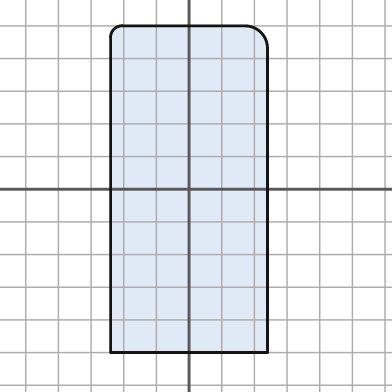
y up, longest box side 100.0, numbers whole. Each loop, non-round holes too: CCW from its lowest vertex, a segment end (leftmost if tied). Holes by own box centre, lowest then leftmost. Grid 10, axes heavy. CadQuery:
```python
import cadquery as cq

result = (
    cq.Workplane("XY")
    .moveTo(-24.0, -50.0)
    .lineTo(24.0, -50.0)
    .lineTo(24.0, 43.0)
    .threePointArc((22.0, 48.0), (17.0, 50.0))
    .lineTo(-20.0, 50.0)
    .threePointArc((-23.0, 49.0), (-24.0, 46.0))
    .close()
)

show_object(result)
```